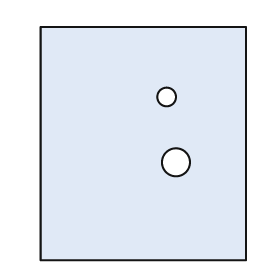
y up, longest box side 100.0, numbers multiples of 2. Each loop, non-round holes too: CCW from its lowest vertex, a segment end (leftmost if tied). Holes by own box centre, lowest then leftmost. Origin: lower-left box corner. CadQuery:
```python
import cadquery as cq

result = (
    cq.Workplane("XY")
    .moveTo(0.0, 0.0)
    .lineTo(88.0, 0.0)
    .lineTo(88.0, 100.0)
    .lineTo(0.0, 100.0)
    .close()
    .moveTo(58.0, 42.0)
    .circle(6.0)
    .moveTo(54.0, 70.0)
    .circle(4.0)
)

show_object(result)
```